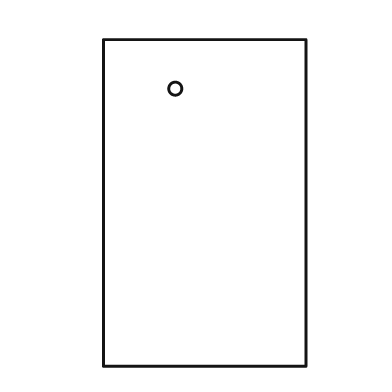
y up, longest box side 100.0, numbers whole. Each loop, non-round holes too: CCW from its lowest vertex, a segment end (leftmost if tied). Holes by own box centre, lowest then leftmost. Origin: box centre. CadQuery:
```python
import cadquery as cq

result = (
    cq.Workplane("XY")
    .moveTo(-31.0, -50.0)
    .lineTo(31.0, -50.0)
    .lineTo(31.0, 50.0)
    .lineTo(-31.0, 50.0)
    .close()
    .moveTo(-9.0, 35.0)
    .circle(2.0)
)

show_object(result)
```